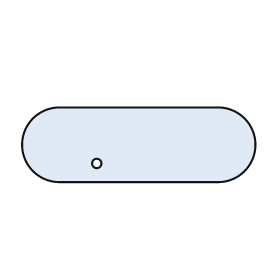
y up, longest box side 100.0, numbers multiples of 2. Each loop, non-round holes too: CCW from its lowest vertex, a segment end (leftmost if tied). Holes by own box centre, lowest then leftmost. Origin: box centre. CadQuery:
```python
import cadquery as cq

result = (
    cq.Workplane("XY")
    .moveTo(-34.0, -16.0)
    .lineTo(34.0, -16.0)
    .threePointArc((50.0, 0.0), (34.0, 16.0))
    .lineTo(-34.0, 16.0)
    .threePointArc((-50.0, 0.0), (-34.0, -16.0))
    .close()
    .moveTo(-18.0, -8.0)
    .circle(2.0)
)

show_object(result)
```